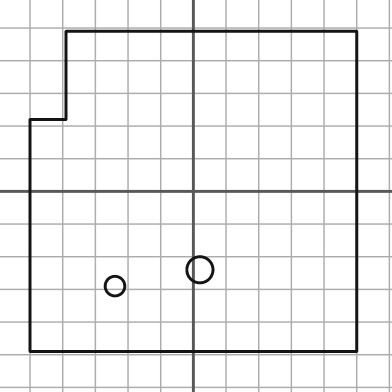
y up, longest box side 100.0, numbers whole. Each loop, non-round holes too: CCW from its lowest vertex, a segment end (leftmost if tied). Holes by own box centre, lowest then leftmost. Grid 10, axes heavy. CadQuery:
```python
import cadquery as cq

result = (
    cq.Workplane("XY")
    .moveTo(-50.0, -49.0)
    .lineTo(50.0, -49.0)
    .lineTo(50.0, 49.0)
    .lineTo(-39.0, 49.0)
    .lineTo(-39.0, 22.0)
    .lineTo(-50.0, 22.0)
    .close()
    .moveTo(-24.0, -29.0)
    .circle(3.0)
    .moveTo(2.0, -24.0)
    .circle(4.0)
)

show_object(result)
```